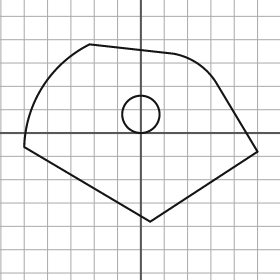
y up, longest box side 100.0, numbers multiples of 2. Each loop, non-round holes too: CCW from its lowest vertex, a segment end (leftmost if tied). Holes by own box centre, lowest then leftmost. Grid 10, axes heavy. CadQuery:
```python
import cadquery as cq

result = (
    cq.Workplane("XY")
    .moveTo(4.0, -38.0)
    .lineTo(50.0, -8.0)
    .lineTo(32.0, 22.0)
    .threePointArc((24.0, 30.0), (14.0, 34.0))
    .lineTo(-22.0, 38.0)
    .threePointArc((-42.0, 20.0), (-50.0, -6.0))
    .close()
    .moveTo(0.0, 8.0)
    .circle(8.0)
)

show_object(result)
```